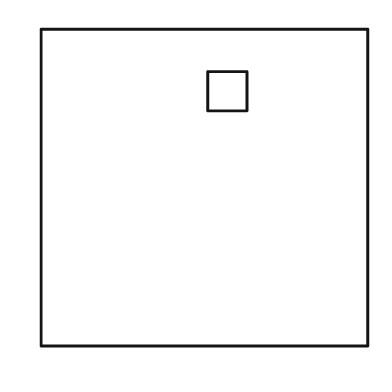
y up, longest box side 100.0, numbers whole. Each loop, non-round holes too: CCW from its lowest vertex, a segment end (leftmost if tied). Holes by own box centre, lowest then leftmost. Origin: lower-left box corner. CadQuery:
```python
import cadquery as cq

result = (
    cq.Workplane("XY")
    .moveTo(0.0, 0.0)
    .lineTo(100.0, 0.0)
    .lineTo(100.0, 97.0)
    .lineTo(0.0, 97.0)
    .close()
    .moveTo(51.0, 72.0)
    .lineTo(63.0, 72.0)
    .lineTo(63.0, 84.0)
    .lineTo(51.0, 84.0)
    .close()
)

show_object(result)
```